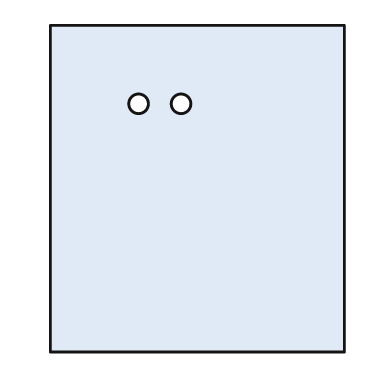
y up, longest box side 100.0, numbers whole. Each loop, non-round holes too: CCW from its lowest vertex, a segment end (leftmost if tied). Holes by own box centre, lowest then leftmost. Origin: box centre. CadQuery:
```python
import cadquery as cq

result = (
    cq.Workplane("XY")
    .moveTo(-45.0, -50.0)
    .lineTo(45.0, -50.0)
    .lineTo(45.0, 50.0)
    .lineTo(-45.0, 50.0)
    .close()
    .moveTo(-18.0, 26.0)
    .circle(3.0)
    .moveTo(-5.0, 26.0)
    .circle(3.0)
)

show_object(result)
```